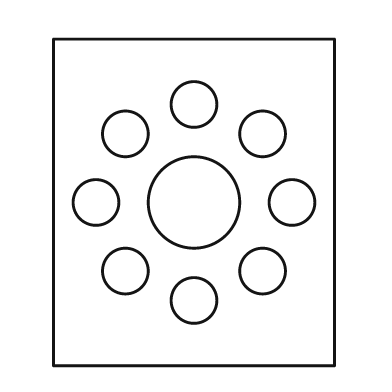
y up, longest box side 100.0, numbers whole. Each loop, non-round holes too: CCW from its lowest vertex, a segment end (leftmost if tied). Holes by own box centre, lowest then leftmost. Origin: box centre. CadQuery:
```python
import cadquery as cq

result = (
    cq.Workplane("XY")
    .moveTo(-43.0, -50.0)
    .lineTo(43.0, -50.0)
    .lineTo(43.0, 50.0)
    .lineTo(-43.0, 50.0)
    .close()
    .moveTo(0.0, -30.0)
    .circle(7.0)
    .moveTo(-21.0, -21.0)
    .circle(7.0)
    .moveTo(21.0, -21.0)
    .circle(7.0)
    .moveTo(-30.0, 0.0)
    .circle(7.0)
    .moveTo(0.0, 0.0)
    .circle(14.0)
    .moveTo(30.0, 0.0)
    .circle(7.0)
    .moveTo(-21.0, 21.0)
    .circle(7.0)
    .moveTo(21.0, 21.0)
    .circle(7.0)
    .moveTo(0.0, 30.0)
    .circle(7.0)
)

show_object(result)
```